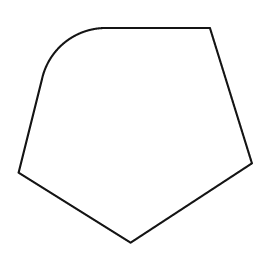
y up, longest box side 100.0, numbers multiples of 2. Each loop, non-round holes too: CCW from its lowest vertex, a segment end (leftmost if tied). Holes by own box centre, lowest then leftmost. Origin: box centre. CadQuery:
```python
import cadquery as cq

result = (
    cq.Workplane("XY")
    .moveTo(-2.0, -46.0)
    .lineTo(50.0, -12.0)
    .lineTo(32.0, 46.0)
    .lineTo(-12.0, 46.0)
    .threePointArc((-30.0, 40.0), (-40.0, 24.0))
    .lineTo(-50.0, -16.0)
    .close()
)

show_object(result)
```